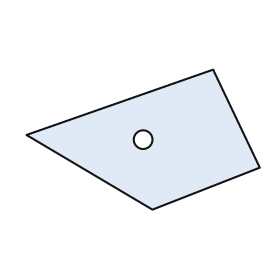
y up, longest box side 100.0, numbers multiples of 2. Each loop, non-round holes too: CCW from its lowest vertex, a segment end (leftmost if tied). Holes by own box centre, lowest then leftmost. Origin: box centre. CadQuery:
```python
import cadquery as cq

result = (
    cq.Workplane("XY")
    .moveTo(4.0, -30.0)
    .lineTo(50.0, -12.0)
    .lineTo(30.0, 30.0)
    .lineTo(-50.0, 2.0)
    .close()
    .moveTo(0.0, 0.0)
    .circle(4.0)
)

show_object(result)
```